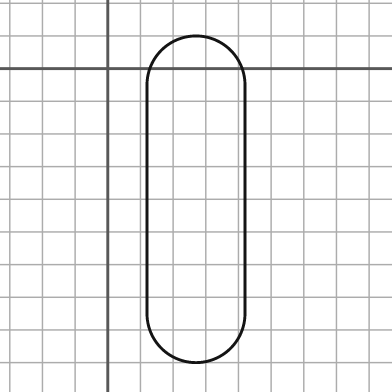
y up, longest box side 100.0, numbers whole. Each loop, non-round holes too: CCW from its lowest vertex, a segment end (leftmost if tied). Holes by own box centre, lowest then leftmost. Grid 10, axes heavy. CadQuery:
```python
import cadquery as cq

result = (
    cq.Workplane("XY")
    .moveTo(12.0, -75.0)
    .threePointArc((27.0, -90.0), (42.0, -75.0))
    .lineTo(42.0, -5.0)
    .threePointArc((27.0, 10.0), (12.0, -5.0))
    .close()
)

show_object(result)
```